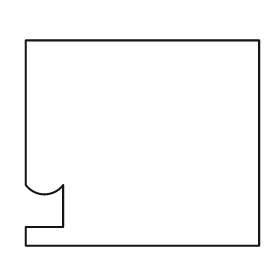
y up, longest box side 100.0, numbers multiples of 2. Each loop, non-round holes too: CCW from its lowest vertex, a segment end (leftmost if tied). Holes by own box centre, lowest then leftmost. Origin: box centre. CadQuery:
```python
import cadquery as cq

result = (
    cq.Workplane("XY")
    .moveTo(-50.0, -44.0)
    .lineTo(50.0, -44.0)
    .lineTo(50.0, 44.0)
    .lineTo(-50.0, 44.0)
    .lineTo(-50.0, -18.0)
    .threePointArc((-42.0, -22.0), (-34.0, -18.0))
    .lineTo(-34.0, -36.0)
    .lineTo(-50.0, -36.0)
    .close()
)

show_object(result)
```